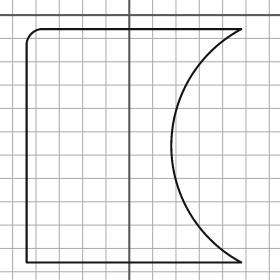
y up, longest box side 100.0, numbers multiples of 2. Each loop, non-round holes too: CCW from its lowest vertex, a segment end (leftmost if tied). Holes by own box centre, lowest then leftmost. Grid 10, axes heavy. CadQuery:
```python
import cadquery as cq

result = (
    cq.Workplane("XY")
    .moveTo(-44.0, -106.0)
    .lineTo(48.0, -106.0)
    .threePointArc((18.0, -56.0), (48.0, -6.0))
    .lineTo(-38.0, -6.0)
    .threePointArc((-42.0, -8.0), (-44.0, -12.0))
    .close()
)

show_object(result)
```